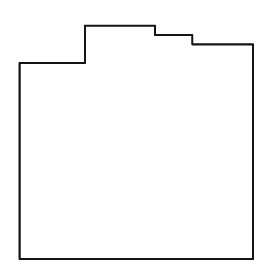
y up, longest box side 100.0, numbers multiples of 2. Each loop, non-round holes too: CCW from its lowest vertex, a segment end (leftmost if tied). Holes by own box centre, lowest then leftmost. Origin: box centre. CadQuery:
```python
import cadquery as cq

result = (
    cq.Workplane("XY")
    .moveTo(-50.0, -50.0)
    .lineTo(50.0, -50.0)
    .lineTo(50.0, 42.0)
    .lineTo(24.0, 42.0)
    .lineTo(24.0, 46.0)
    .lineTo(8.0, 46.0)
    .lineTo(8.0, 50.0)
    .lineTo(-22.0, 50.0)
    .lineTo(-22.0, 34.0)
    .lineTo(-50.0, 34.0)
    .close()
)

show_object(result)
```